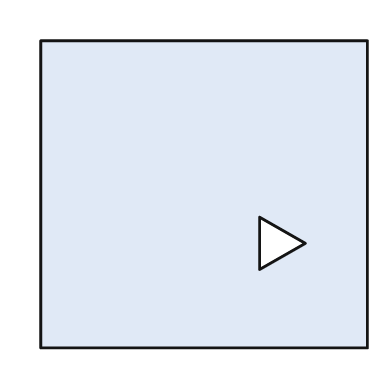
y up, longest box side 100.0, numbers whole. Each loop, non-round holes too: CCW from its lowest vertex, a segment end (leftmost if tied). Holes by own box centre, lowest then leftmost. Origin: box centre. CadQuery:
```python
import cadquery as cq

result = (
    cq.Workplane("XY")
    .moveTo(-50.0, -47.0)
    .lineTo(50.0, -47.0)
    .lineTo(50.0, 47.0)
    .lineTo(-50.0, 47.0)
    .close()
    .moveTo(17.0, -23.0)
    .lineTo(31.0, -15.0)
    .lineTo(17.0, -7.0)
    .close()
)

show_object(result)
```